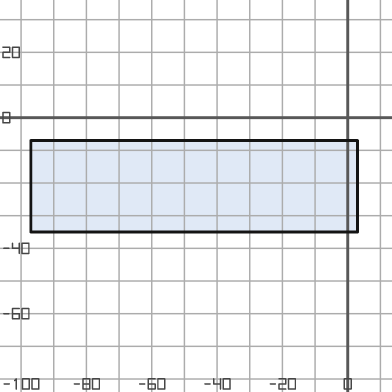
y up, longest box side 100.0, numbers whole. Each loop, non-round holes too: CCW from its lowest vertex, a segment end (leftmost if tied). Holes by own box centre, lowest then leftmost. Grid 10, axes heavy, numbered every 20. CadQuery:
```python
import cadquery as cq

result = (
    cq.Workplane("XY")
    .moveTo(-97.0, -35.0)
    .lineTo(3.0, -35.0)
    .lineTo(3.0, -7.0)
    .lineTo(-97.0, -7.0)
    .close()
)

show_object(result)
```